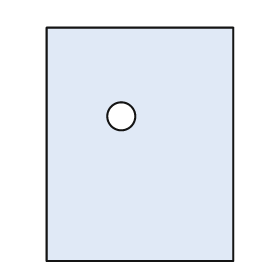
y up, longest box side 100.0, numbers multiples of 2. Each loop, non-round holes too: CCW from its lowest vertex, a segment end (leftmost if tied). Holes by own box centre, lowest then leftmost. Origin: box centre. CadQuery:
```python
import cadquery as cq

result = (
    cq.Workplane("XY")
    .moveTo(-40.0, -50.0)
    .lineTo(40.0, -50.0)
    .lineTo(40.0, 50.0)
    .lineTo(-40.0, 50.0)
    .close()
    .moveTo(-8.0, 12.0)
    .circle(6.0)
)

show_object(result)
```